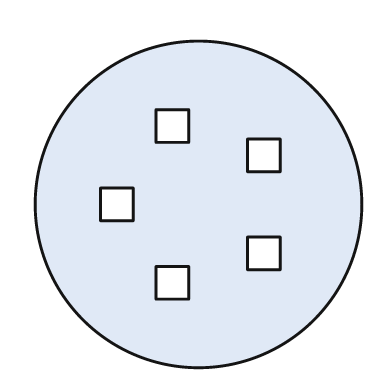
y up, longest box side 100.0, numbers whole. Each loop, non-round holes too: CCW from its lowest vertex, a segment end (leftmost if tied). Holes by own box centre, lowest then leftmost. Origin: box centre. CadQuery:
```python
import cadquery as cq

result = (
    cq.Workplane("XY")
    .moveTo(0.0, 0.0)
    .circle(50.0)
    .moveTo(-13.0, -29.0)
    .lineTo(-3.0, -29.0)
    .lineTo(-3.0, -19.0)
    .lineTo(-13.0, -19.0)
    .close()
    .moveTo(15.0, -20.0)
    .lineTo(25.0, -20.0)
    .lineTo(25.0, -10.0)
    .lineTo(15.0, -10.0)
    .close()
    .moveTo(-30.0, -5.0)
    .lineTo(-20.0, -5.0)
    .lineTo(-20.0, 5.0)
    .lineTo(-30.0, 5.0)
    .close()
    .moveTo(15.0, 10.0)
    .lineTo(25.0, 10.0)
    .lineTo(25.0, 20.0)
    .lineTo(15.0, 20.0)
    .close()
    .moveTo(-13.0, 19.0)
    .lineTo(-3.0, 19.0)
    .lineTo(-3.0, 29.0)
    .lineTo(-13.0, 29.0)
    .close()
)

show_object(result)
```